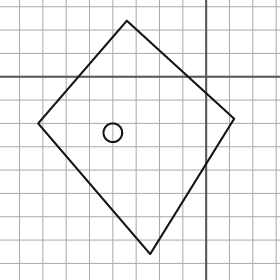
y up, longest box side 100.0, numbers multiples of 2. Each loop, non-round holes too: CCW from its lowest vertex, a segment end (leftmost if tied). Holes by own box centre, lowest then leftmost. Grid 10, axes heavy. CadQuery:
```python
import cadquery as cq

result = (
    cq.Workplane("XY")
    .moveTo(-24.0, -76.0)
    .lineTo(12.0, -18.0)
    .lineTo(-34.0, 24.0)
    .lineTo(-72.0, -20.0)
    .close()
    .moveTo(-40.0, -24.0)
    .circle(4.0)
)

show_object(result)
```